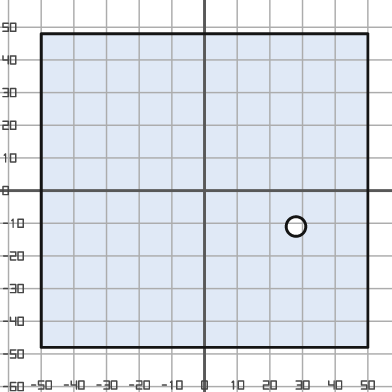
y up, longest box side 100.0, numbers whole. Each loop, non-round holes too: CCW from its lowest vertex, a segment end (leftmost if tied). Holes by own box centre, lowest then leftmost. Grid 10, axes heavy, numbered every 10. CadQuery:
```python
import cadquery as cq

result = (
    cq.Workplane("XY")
    .moveTo(-50.0, -48.0)
    .lineTo(50.0, -48.0)
    .lineTo(50.0, 48.0)
    .lineTo(-50.0, 48.0)
    .close()
    .moveTo(28.0, -11.0)
    .circle(3.0)
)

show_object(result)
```